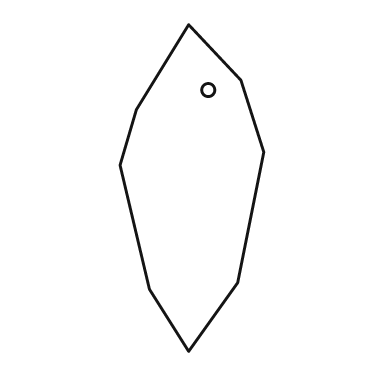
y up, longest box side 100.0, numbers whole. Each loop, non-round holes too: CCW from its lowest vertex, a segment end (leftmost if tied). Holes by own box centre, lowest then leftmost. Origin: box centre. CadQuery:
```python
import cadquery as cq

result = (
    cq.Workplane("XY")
    .moveTo(-1.0, -50.0)
    .lineTo(14.0, -29.0)
    .lineTo(22.0, 11.0)
    .lineTo(15.0, 33.0)
    .lineTo(-1.0, 50.0)
    .lineTo(-17.0, 24.0)
    .lineTo(-22.0, 7.0)
    .lineTo(-13.0, -31.0)
    .close()
    .moveTo(5.0, 30.0)
    .circle(2.0)
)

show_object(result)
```